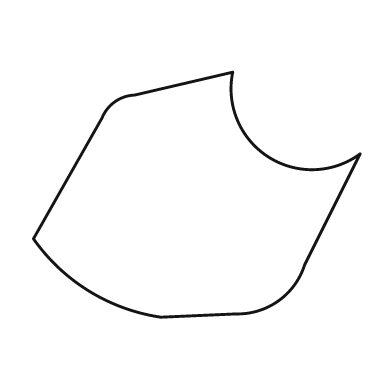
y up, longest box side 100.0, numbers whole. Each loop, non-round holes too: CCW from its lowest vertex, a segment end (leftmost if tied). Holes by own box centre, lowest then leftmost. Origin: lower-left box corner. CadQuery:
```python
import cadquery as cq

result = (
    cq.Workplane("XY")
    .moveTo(39.0, 0.0)
    .lineTo(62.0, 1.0)
    .threePointArc((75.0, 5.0), (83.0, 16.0))
    .lineTo(100.0, 50.0)
    .threePointArc((72.0, 49.0), (61.0, 75.0))
    .lineTo(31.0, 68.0)
    .threePointArc((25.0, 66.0), (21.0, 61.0))
    .lineTo(0.0, 24.0)
    .threePointArc((17.0, 8.0), (39.0, 0.0))
    .close()
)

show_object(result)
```